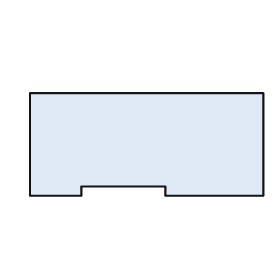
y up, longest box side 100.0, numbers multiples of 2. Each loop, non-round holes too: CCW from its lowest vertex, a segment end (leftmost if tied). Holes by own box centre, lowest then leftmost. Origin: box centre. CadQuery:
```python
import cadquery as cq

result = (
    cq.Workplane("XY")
    .moveTo(-50.0, -22.0)
    .lineTo(-28.0, -22.0)
    .lineTo(-28.0, -18.0)
    .lineTo(8.0, -18.0)
    .lineTo(8.0, -22.0)
    .lineTo(50.0, -22.0)
    .lineTo(50.0, 22.0)
    .lineTo(-50.0, 22.0)
    .close()
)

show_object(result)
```